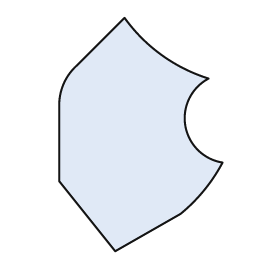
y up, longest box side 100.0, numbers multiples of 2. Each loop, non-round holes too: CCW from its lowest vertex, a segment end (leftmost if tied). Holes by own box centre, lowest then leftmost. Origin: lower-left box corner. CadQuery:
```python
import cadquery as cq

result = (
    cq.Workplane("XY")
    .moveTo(24.0, 0.0)
    .lineTo(52.0, 16.0)
    .threePointArc((62.0, 26.0), (70.0, 38.0))
    .threePointArc((54.0, 54.0), (64.0, 74.0))
    .threePointArc((44.0, 84.0), (28.0, 100.0))
    .lineTo(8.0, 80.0)
    .threePointArc((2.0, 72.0), (0.0, 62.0))
    .lineTo(0.0, 30.0)
    .close()
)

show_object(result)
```